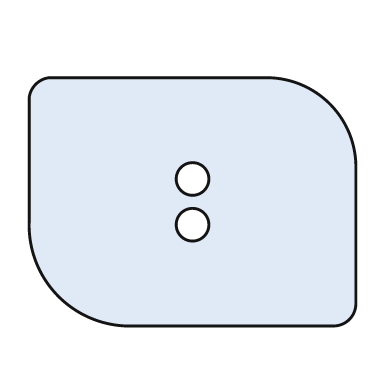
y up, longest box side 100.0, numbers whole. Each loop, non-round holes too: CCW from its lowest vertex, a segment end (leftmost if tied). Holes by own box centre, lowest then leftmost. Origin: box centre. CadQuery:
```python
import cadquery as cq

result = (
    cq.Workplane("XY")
    .moveTo(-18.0, -38.0)
    .lineTo(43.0, -38.0)
    .threePointArc((48.0, -36.0), (50.0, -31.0))
    .lineTo(50.0, 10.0)
    .threePointArc((42.0, 30.0), (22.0, 38.0))
    .lineTo(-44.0, 38.0)
    .threePointArc((-48.0, 36.0), (-50.0, 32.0))
    .lineTo(-50.0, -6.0)
    .threePointArc((-41.0, -29.0), (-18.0, -38.0))
    .close()
    .moveTo(0.0, -7.0)
    .circle(5.0)
    .moveTo(0.0, 7.0)
    .circle(5.0)
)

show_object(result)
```